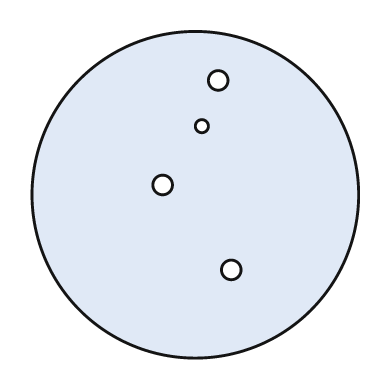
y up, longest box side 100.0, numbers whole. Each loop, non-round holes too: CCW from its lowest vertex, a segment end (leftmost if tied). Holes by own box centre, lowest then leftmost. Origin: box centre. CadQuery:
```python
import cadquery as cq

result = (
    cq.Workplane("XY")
    .moveTo(0.0, 0.0)
    .circle(50.0)
    .moveTo(11.0, -23.0)
    .circle(3.0)
    .moveTo(-10.0, 3.0)
    .circle(3.0)
    .moveTo(2.0, 21.0)
    .circle(2.0)
    .moveTo(7.0, 35.0)
    .circle(3.0)
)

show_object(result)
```